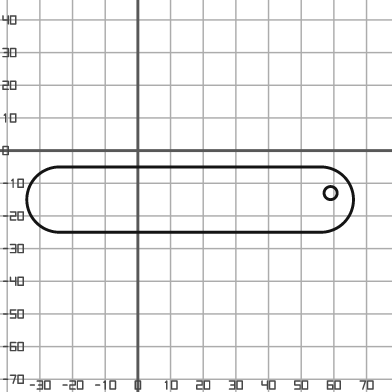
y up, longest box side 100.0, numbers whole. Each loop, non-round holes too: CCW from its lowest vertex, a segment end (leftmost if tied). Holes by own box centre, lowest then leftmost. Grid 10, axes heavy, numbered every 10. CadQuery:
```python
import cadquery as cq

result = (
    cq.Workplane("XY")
    .moveTo(-24.0, -25.0)
    .lineTo(56.0, -25.0)
    .threePointArc((66.0, -15.0), (56.0, -5.0))
    .lineTo(-24.0, -5.0)
    .threePointArc((-34.0, -15.0), (-24.0, -25.0))
    .close()
    .moveTo(59.0, -13.0)
    .circle(2.0)
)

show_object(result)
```